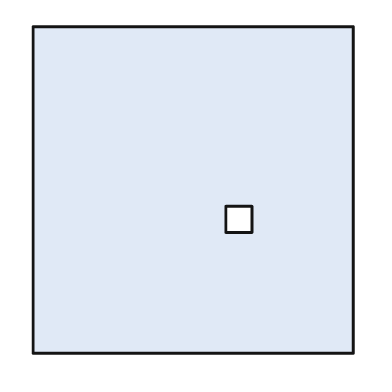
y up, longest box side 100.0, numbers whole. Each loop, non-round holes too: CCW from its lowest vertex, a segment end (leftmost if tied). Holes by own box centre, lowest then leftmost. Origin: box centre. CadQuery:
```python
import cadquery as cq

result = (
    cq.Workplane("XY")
    .moveTo(-49.0, -50.0)
    .lineTo(49.0, -50.0)
    .lineTo(49.0, 50.0)
    .lineTo(-49.0, 50.0)
    .close()
    .moveTo(10.0, -13.0)
    .lineTo(18.0, -13.0)
    .lineTo(18.0, -5.0)
    .lineTo(10.0, -5.0)
    .close()
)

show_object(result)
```